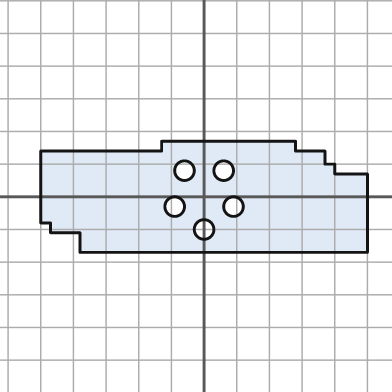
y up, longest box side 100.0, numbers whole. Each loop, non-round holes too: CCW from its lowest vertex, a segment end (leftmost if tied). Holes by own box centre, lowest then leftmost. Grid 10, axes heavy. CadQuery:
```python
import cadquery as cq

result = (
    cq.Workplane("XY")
    .moveTo(-38.0, -17.0)
    .lineTo(50.0, -17.0)
    .lineTo(50.0, 7.0)
    .lineTo(40.0, 7.0)
    .lineTo(40.0, 10.0)
    .lineTo(37.0, 10.0)
    .lineTo(37.0, 14.0)
    .lineTo(28.0, 14.0)
    .lineTo(28.0, 17.0)
    .lineTo(-13.0, 17.0)
    .lineTo(-13.0, 14.0)
    .lineTo(-50.0, 14.0)
    .lineTo(-50.0, -8.0)
    .lineTo(-47.0, -8.0)
    .lineTo(-47.0, -11.0)
    .lineTo(-38.0, -11.0)
    .close()
    .moveTo(0.0, -10.0)
    .circle(3.0)
    .moveTo(-9.0, -3.0)
    .circle(3.0)
    .moveTo(9.0, -3.0)
    .circle(3.0)
    .moveTo(-6.0, 8.0)
    .circle(3.0)
    .moveTo(6.0, 8.0)
    .circle(3.0)
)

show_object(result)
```